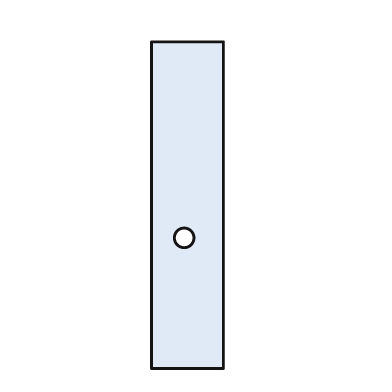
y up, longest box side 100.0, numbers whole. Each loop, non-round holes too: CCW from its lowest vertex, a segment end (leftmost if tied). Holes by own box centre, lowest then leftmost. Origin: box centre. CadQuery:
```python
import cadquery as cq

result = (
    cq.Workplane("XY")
    .moveTo(-11.0, -50.0)
    .lineTo(11.0, -50.0)
    .lineTo(11.0, 50.0)
    .lineTo(-11.0, 50.0)
    .close()
    .moveTo(-1.0, -10.0)
    .circle(3.0)
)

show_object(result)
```